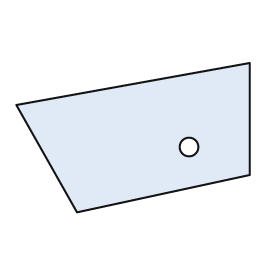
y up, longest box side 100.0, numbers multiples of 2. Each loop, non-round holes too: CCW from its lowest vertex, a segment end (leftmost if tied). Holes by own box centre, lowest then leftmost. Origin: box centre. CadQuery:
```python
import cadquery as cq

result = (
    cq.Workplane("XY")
    .moveTo(-24.0, -32.0)
    .lineTo(50.0, -16.0)
    .lineTo(50.0, 32.0)
    .lineTo(-50.0, 14.0)
    .close()
    .moveTo(24.0, -4.0)
    .circle(4.0)
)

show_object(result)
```